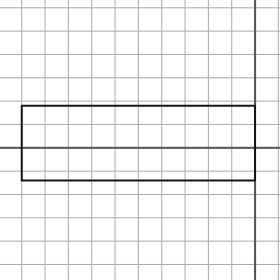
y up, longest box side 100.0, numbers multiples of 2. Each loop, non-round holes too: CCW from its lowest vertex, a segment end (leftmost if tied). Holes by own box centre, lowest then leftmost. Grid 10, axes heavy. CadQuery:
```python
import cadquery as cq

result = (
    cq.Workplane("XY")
    .moveTo(-100.0, -14.0)
    .lineTo(0.0, -14.0)
    .lineTo(0.0, 18.0)
    .lineTo(-100.0, 18.0)
    .close()
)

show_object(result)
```